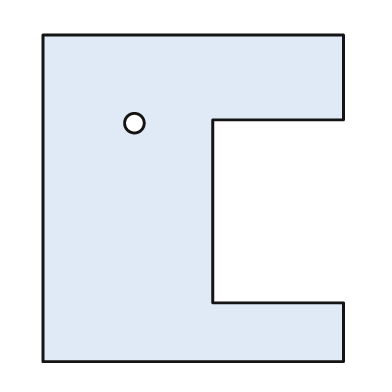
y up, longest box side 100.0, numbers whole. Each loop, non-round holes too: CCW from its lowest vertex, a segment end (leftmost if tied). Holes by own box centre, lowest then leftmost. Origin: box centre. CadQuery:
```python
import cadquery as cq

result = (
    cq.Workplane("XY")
    .moveTo(-46.0, -50.0)
    .lineTo(46.0, -50.0)
    .lineTo(46.0, -32.0)
    .lineTo(6.0, -32.0)
    .lineTo(6.0, 24.0)
    .lineTo(46.0, 24.0)
    .lineTo(46.0, 50.0)
    .lineTo(-46.0, 50.0)
    .close()
    .moveTo(-18.0, 23.0)
    .circle(3.0)
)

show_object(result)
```